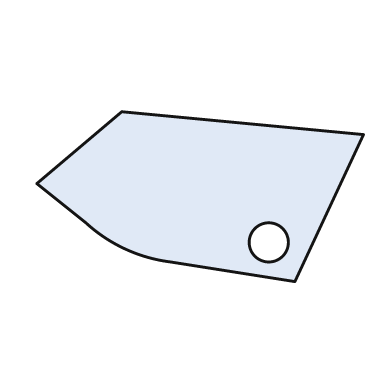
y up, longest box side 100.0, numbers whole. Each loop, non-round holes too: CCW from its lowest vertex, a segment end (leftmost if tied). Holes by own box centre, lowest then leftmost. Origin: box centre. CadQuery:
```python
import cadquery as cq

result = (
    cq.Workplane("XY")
    .moveTo(29.0, -26.0)
    .lineTo(50.0, 19.0)
    .lineTo(-24.0, 26.0)
    .lineTo(-50.0, 4.0)
    .lineTo(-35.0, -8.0)
    .threePointArc((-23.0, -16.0), (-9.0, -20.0))
    .close()
    .moveTo(21.0, -14.0)
    .circle(6.0)
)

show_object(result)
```